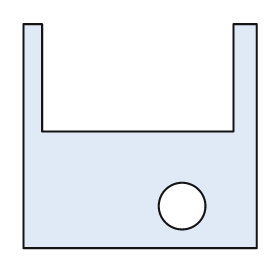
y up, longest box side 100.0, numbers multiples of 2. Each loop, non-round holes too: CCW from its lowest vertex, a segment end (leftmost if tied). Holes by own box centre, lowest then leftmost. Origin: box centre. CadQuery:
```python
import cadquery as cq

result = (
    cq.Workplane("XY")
    .moveTo(-50.0, -48.0)
    .lineTo(50.0, -48.0)
    .lineTo(50.0, 48.0)
    .lineTo(40.0, 48.0)
    .lineTo(40.0, 2.0)
    .lineTo(-42.0, 2.0)
    .lineTo(-42.0, 48.0)
    .lineTo(-50.0, 48.0)
    .close()
    .moveTo(18.0, -30.0)
    .circle(10.0)
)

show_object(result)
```